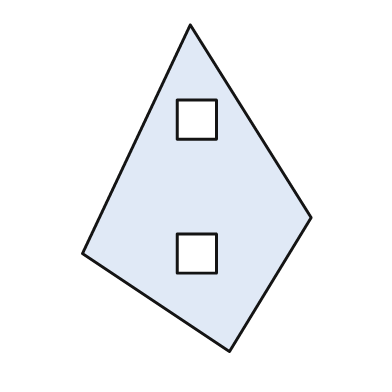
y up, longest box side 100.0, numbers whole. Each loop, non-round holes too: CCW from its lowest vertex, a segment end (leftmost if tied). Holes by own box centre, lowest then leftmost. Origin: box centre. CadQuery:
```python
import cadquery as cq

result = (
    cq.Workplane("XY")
    .moveTo(10.0, -50.0)
    .lineTo(35.0, -9.0)
    .lineTo(-2.0, 50.0)
    .lineTo(-35.0, -20.0)
    .close()
    .moveTo(-6.0, -26.0)
    .lineTo(6.0, -26.0)
    .lineTo(6.0, -14.0)
    .lineTo(-6.0, -14.0)
    .close()
    .moveTo(-6.0, 15.0)
    .lineTo(6.0, 15.0)
    .lineTo(6.0, 27.0)
    .lineTo(-6.0, 27.0)
    .close()
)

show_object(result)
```